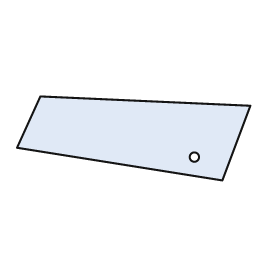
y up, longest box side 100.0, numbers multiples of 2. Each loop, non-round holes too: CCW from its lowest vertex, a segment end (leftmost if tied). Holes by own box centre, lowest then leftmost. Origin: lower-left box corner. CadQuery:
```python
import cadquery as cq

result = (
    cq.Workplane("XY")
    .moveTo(88.0, 0.0)
    .lineTo(100.0, 32.0)
    .lineTo(10.0, 36.0)
    .lineTo(0.0, 14.0)
    .close()
    .moveTo(76.0, 10.0)
    .circle(2.0)
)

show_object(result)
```